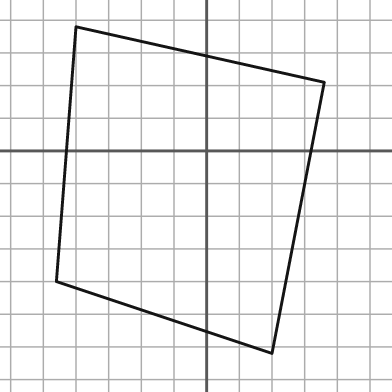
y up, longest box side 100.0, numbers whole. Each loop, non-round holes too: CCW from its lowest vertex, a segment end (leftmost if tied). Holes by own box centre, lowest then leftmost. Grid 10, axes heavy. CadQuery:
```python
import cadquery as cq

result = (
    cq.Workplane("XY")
    .moveTo(20.0, -62.0)
    .lineTo(36.0, 21.0)
    .lineTo(-40.0, 38.0)
    .lineTo(-46.0, -40.0)
    .close()
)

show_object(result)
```